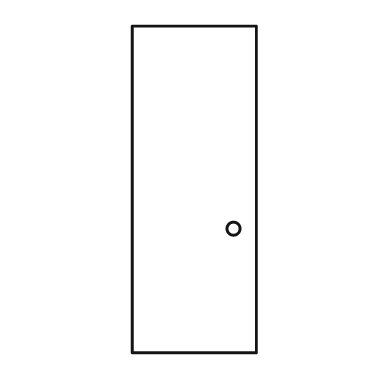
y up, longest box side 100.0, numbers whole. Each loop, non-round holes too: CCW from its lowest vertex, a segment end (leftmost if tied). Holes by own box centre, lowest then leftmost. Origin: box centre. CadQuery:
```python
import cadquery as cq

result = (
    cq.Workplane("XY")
    .moveTo(-19.0, -50.0)
    .lineTo(19.0, -50.0)
    .lineTo(19.0, 50.0)
    .lineTo(-19.0, 50.0)
    .close()
    .moveTo(12.0, -12.0)
    .circle(2.0)
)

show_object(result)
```